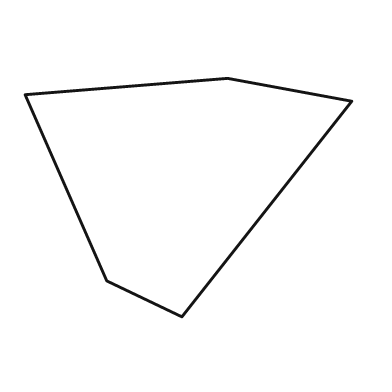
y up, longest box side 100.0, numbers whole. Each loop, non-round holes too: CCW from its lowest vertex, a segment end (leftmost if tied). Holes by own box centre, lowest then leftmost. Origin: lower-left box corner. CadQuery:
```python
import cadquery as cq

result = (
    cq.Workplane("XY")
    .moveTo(48.0, 0.0)
    .lineTo(100.0, 66.0)
    .lineTo(62.0, 73.0)
    .lineTo(0.0, 68.0)
    .lineTo(25.0, 11.0)
    .close()
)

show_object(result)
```